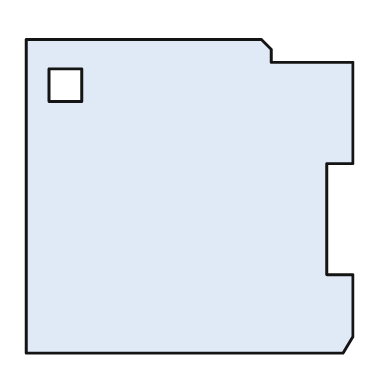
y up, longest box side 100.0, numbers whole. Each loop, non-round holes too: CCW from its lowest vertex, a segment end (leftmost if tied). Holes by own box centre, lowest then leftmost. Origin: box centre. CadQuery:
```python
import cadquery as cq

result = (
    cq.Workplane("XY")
    .moveTo(-50.0, -48.0)
    .lineTo(47.0, -48.0)
    .lineTo(50.0, -43.0)
    .lineTo(50.0, -24.0)
    .lineTo(42.0, -24.0)
    .lineTo(42.0, 10.0)
    .lineTo(50.0, 10.0)
    .lineTo(50.0, 41.0)
    .lineTo(25.0, 41.0)
    .lineTo(25.0, 45.0)
    .lineTo(22.0, 48.0)
    .lineTo(-50.0, 48.0)
    .close()
    .moveTo(-43.0, 29.0)
    .lineTo(-33.0, 29.0)
    .lineTo(-33.0, 39.0)
    .lineTo(-43.0, 39.0)
    .close()
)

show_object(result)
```